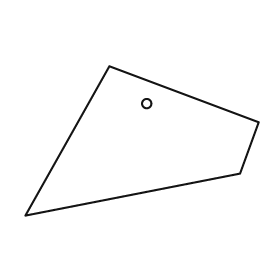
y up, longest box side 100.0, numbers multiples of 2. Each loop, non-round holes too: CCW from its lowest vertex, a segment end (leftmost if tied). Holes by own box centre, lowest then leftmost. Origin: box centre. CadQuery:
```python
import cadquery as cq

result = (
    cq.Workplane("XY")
    .moveTo(-50.0, -32.0)
    .lineTo(42.0, -14.0)
    .lineTo(50.0, 8.0)
    .lineTo(-14.0, 32.0)
    .close()
    .moveTo(2.0, 16.0)
    .circle(2.0)
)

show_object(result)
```